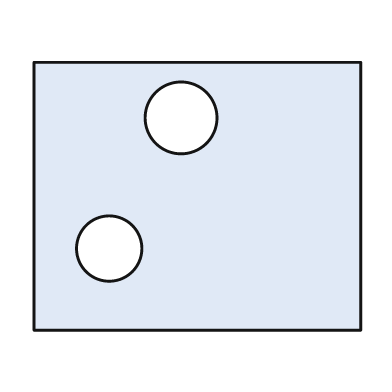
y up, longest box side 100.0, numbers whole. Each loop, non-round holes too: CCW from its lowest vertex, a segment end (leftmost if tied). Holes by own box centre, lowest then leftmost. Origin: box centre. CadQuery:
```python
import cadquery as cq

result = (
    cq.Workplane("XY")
    .moveTo(-50.0, -41.0)
    .lineTo(50.0, -41.0)
    .lineTo(50.0, 41.0)
    .lineTo(-50.0, 41.0)
    .close()
    .moveTo(-27.0, -16.0)
    .circle(10.0)
    .moveTo(-5.0, 24.0)
    .circle(11.0)
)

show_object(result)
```